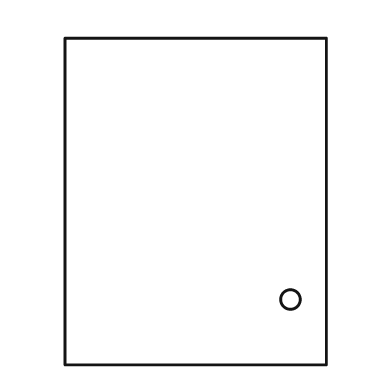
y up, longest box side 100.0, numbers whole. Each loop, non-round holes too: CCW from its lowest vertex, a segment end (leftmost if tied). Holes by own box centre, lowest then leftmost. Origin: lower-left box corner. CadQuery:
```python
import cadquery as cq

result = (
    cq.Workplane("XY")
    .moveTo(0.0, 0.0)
    .lineTo(80.0, 0.0)
    .lineTo(80.0, 100.0)
    .lineTo(0.0, 100.0)
    .close()
    .moveTo(69.0, 20.0)
    .circle(3.0)
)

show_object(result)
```